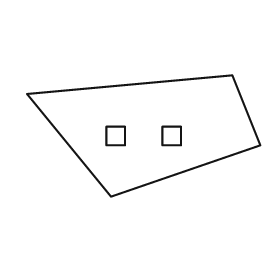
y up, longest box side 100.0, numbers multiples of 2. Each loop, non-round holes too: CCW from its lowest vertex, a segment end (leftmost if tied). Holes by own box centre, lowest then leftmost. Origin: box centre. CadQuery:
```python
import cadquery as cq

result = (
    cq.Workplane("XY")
    .moveTo(-14.0, -26.0)
    .lineTo(50.0, -4.0)
    .lineTo(38.0, 26.0)
    .lineTo(-50.0, 18.0)
    .close()
    .moveTo(-16.0, -4.0)
    .lineTo(-8.0, -4.0)
    .lineTo(-8.0, 4.0)
    .lineTo(-16.0, 4.0)
    .close()
    .moveTo(8.0, -4.0)
    .lineTo(16.0, -4.0)
    .lineTo(16.0, 4.0)
    .lineTo(8.0, 4.0)
    .close()
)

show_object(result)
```